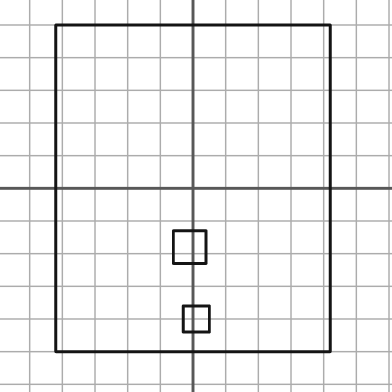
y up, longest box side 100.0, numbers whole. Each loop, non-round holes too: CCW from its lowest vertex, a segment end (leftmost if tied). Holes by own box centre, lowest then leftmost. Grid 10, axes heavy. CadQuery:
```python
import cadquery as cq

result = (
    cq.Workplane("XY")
    .moveTo(-42.0, -50.0)
    .lineTo(42.0, -50.0)
    .lineTo(42.0, 50.0)
    .lineTo(-42.0, 50.0)
    .close()
    .moveTo(-3.0, -44.0)
    .lineTo(5.0, -44.0)
    .lineTo(5.0, -36.0)
    .lineTo(-3.0, -36.0)
    .close()
    .moveTo(-6.0, -23.0)
    .lineTo(4.0, -23.0)
    .lineTo(4.0, -13.0)
    .lineTo(-6.0, -13.0)
    .close()
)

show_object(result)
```